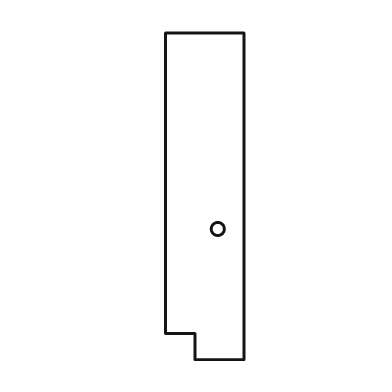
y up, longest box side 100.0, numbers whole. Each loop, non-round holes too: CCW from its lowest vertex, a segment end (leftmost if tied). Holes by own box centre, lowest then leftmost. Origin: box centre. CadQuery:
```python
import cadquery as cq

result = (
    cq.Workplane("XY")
    .moveTo(-3.0, -50.0)
    .lineTo(12.0, -50.0)
    .lineTo(12.0, 50.0)
    .lineTo(-12.0, 50.0)
    .lineTo(-12.0, -42.0)
    .lineTo(-3.0, -42.0)
    .close()
    .moveTo(4.0, -10.0)
    .circle(2.0)
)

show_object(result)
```